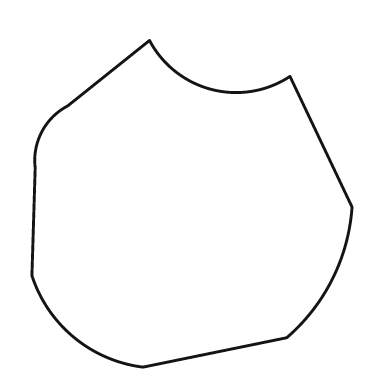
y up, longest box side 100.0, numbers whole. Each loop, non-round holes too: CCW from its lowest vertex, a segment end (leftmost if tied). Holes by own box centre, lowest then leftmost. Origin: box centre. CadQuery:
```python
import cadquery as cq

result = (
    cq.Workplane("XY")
    .moveTo(-15.0, -50.0)
    .lineTo(29.0, -41.0)
    .threePointArc((43.0, -23.0), (49.0, -1.0))
    .lineTo(30.0, 39.0)
    .threePointArc((6.0, 35.0), (-13.0, 50.0))
    .lineTo(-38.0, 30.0)
    .threePointArc((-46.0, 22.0), (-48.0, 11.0))
    .lineTo(-49.0, -22.0)
    .threePointArc((-36.0, -41.0), (-15.0, -50.0))
    .close()
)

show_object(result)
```